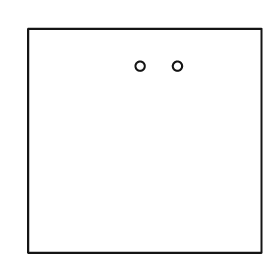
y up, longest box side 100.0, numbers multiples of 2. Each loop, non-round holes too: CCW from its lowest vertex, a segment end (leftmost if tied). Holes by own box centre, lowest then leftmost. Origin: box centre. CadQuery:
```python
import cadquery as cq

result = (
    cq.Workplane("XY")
    .moveTo(-50.0, -48.0)
    .lineTo(50.0, -48.0)
    .lineTo(50.0, 48.0)
    .lineTo(-50.0, 48.0)
    .close()
    .moveTo(-2.0, 32.0)
    .circle(2.0)
    .moveTo(14.0, 32.0)
    .circle(2.0)
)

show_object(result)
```